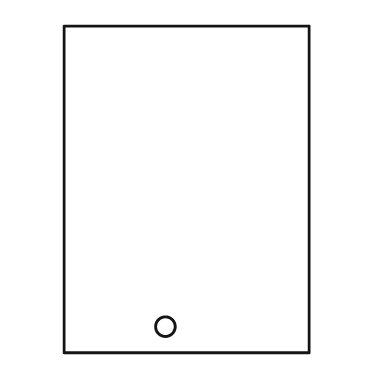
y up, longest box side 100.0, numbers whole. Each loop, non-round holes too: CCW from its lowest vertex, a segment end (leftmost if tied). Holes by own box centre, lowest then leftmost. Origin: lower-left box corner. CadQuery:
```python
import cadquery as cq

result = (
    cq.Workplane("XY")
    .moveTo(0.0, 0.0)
    .lineTo(75.0, 0.0)
    .lineTo(75.0, 100.0)
    .lineTo(0.0, 100.0)
    .close()
    .moveTo(31.0, 8.0)
    .circle(3.0)
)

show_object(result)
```